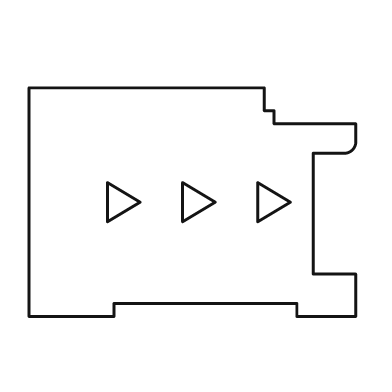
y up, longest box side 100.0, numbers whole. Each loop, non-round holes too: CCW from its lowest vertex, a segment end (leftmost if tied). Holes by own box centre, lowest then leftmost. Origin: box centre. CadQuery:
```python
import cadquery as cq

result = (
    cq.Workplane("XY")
    .moveTo(-50.0, -35.0)
    .lineTo(-24.0, -35.0)
    .lineTo(-24.0, -31.0)
    .lineTo(32.0, -31.0)
    .lineTo(32.0, -35.0)
    .lineTo(50.0, -35.0)
    .lineTo(50.0, -22.0)
    .lineTo(37.0, -22.0)
    .lineTo(37.0, 15.0)
    .lineTo(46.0, 15.0)
    .threePointArc((49.0, 16.0), (50.0, 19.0))
    .lineTo(50.0, 24.0)
    .lineTo(25.0, 24.0)
    .lineTo(25.0, 28.0)
    .lineTo(22.0, 28.0)
    .lineTo(22.0, 35.0)
    .lineTo(-50.0, 35.0)
    .close()
    .moveTo(-26.0, -6.0)
    .lineTo(-16.0, 0.0)
    .lineTo(-26.0, 6.0)
    .close()
    .moveTo(-3.0, -6.0)
    .lineTo(7.0, 0.0)
    .lineTo(-3.0, 6.0)
    .close()
    .moveTo(20.0, -6.0)
    .lineTo(30.0, 0.0)
    .lineTo(20.0, 6.0)
    .close()
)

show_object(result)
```